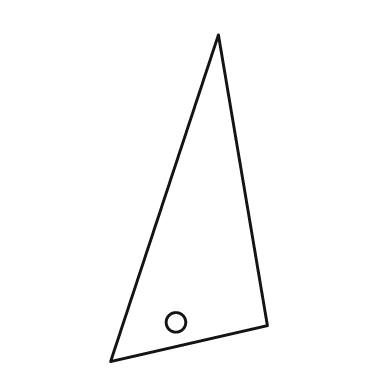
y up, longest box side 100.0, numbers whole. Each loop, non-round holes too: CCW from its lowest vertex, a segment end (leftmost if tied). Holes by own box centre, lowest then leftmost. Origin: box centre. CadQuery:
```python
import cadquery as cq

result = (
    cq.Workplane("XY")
    .moveTo(-24.0, -50.0)
    .lineTo(24.0, -39.0)
    .lineTo(9.0, 50.0)
    .close()
    .moveTo(-4.0, -38.0)
    .circle(3.0)
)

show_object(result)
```